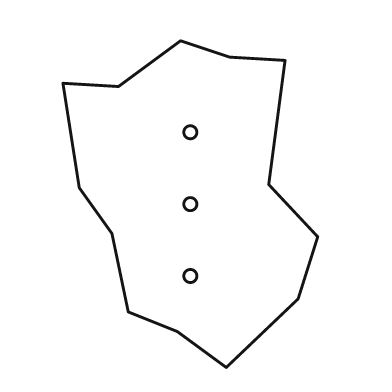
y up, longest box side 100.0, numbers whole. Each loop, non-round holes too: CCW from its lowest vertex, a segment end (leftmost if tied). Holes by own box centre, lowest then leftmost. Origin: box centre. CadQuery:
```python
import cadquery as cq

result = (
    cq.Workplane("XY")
    .moveTo(11.0, -50.0)
    .lineTo(33.0, -29.0)
    .lineTo(39.0, -10.0)
    .lineTo(24.0, 6.0)
    .lineTo(29.0, 44.0)
    .lineTo(12.0, 45.0)
    .lineTo(-3.0, 50.0)
    .lineTo(-22.0, 36.0)
    .lineTo(-39.0, 37.0)
    .lineTo(-34.0, 5.0)
    .lineTo(-24.0, -9.0)
    .lineTo(-19.0, -33.0)
    .lineTo(-4.0, -39.0)
    .close()
    .moveTo(0.0, -22.0)
    .circle(2.0)
    .moveTo(0.0, 0.0)
    .circle(2.0)
    .moveTo(0.0, 22.0)
    .circle(2.0)
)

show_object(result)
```